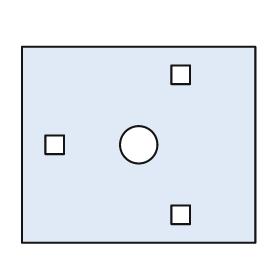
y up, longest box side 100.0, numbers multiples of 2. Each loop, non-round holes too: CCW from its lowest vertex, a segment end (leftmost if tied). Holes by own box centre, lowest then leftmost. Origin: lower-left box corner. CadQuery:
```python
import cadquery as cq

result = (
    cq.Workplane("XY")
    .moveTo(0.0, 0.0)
    .lineTo(100.0, 0.0)
    .lineTo(100.0, 84.0)
    .lineTo(0.0, 84.0)
    .close()
    .moveTo(64.0, 8.0)
    .lineTo(72.0, 8.0)
    .lineTo(72.0, 16.0)
    .lineTo(64.0, 16.0)
    .close()
    .moveTo(10.0, 38.0)
    .lineTo(18.0, 38.0)
    .lineTo(18.0, 46.0)
    .lineTo(10.0, 46.0)
    .close()
    .moveTo(50.0, 42.0)
    .circle(8.0)
    .moveTo(64.0, 68.0)
    .lineTo(72.0, 68.0)
    .lineTo(72.0, 76.0)
    .lineTo(64.0, 76.0)
    .close()
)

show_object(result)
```